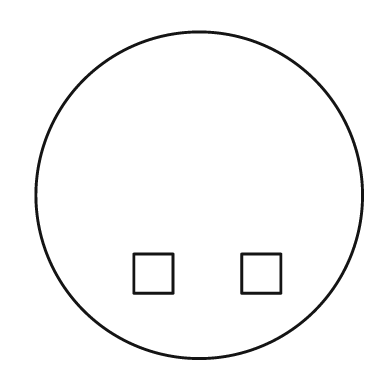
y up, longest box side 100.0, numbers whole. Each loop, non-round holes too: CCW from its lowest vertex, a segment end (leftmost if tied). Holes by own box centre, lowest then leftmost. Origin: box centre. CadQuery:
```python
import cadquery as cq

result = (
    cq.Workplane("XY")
    .moveTo(0.0, 0.0)
    .circle(50.0)
    .moveTo(-20.0, -30.0)
    .lineTo(-8.0, -30.0)
    .lineTo(-8.0, -18.0)
    .lineTo(-20.0, -18.0)
    .close()
    .moveTo(13.0, -30.0)
    .lineTo(25.0, -30.0)
    .lineTo(25.0, -18.0)
    .lineTo(13.0, -18.0)
    .close()
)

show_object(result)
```